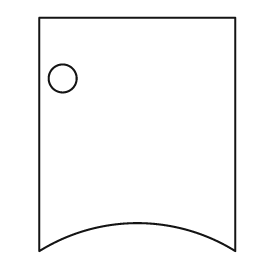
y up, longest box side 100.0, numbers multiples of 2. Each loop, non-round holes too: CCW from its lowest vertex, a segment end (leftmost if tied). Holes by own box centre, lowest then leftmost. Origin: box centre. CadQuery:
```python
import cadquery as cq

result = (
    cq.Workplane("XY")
    .moveTo(-42.0, -50.0)
    .threePointArc((0.0, -38.0), (42.0, -50.0))
    .lineTo(42.0, 50.0)
    .lineTo(-42.0, 50.0)
    .close()
    .moveTo(-32.0, 24.0)
    .circle(6.0)
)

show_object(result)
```